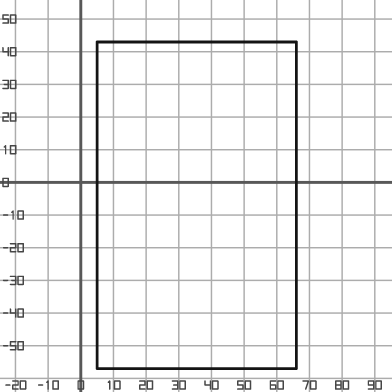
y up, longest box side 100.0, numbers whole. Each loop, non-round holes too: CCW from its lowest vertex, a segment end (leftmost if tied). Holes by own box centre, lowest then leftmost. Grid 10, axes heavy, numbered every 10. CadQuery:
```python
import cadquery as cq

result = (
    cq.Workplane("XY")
    .moveTo(5.0, -57.0)
    .lineTo(66.0, -57.0)
    .lineTo(66.0, 43.0)
    .lineTo(5.0, 43.0)
    .close()
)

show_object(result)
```